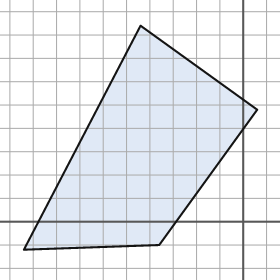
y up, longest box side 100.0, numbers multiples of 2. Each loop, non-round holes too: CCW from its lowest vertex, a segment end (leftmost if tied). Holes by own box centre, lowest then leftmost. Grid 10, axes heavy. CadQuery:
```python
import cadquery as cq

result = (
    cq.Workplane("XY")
    .moveTo(-94.0, -12.0)
    .lineTo(-36.0, -10.0)
    .lineTo(6.0, 48.0)
    .lineTo(-44.0, 84.0)
    .close()
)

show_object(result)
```